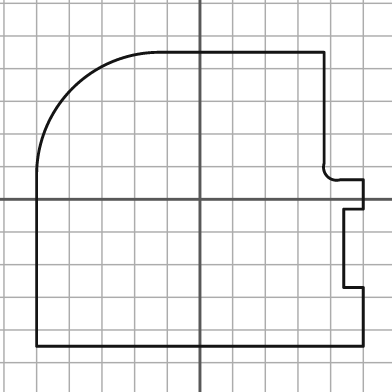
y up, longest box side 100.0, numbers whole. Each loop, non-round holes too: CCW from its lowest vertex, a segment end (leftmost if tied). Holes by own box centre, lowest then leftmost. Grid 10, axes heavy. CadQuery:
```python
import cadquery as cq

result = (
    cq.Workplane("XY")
    .moveTo(-50.0, -45.0)
    .lineTo(50.0, -45.0)
    .lineTo(50.0, -27.0)
    .lineTo(44.0, -27.0)
    .lineTo(44.0, -3.0)
    .lineTo(50.0, -3.0)
    .lineTo(50.0, 6.0)
    .lineTo(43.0, 6.0)
    .threePointArc((39.0, 7.0), (38.0, 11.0))
    .lineTo(38.0, 45.0)
    .lineTo(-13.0, 45.0)
    .threePointArc((-39.0, 34.0), (-50.0, 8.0))
    .close()
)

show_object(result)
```